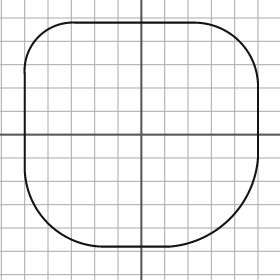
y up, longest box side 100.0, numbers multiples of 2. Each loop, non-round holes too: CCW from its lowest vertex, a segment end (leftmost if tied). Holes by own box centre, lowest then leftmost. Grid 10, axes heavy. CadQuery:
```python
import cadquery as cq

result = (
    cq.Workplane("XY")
    .moveTo(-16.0, -48.0)
    .lineTo(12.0, -48.0)
    .threePointArc((38.0, -36.0), (50.0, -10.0))
    .lineTo(50.0, 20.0)
    .threePointArc((42.0, 40.0), (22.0, 48.0))
    .lineTo(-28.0, 48.0)
    .threePointArc((-44.0, 42.0), (-50.0, 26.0))
    .lineTo(-50.0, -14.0)
    .threePointArc((-40.0, -38.0), (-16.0, -48.0))
    .close()
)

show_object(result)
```